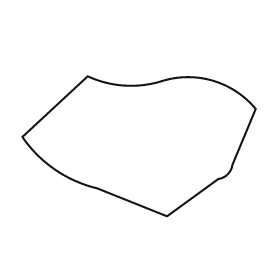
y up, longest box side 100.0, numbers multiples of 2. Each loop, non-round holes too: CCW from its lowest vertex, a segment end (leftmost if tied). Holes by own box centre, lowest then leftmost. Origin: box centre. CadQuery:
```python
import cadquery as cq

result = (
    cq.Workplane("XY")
    .moveTo(12.0, -30.0)
    .lineTo(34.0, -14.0)
    .threePointArc((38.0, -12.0), (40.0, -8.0))
    .lineTo(50.0, 16.0)
    .threePointArc((32.0, 28.0), (10.0, 28.0))
    .threePointArc((-6.0, 26.0), (-22.0, 30.0))
    .lineTo(-50.0, 4.0)
    .threePointArc((-36.0, -10.0), (-18.0, -18.0))
    .close()
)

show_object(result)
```